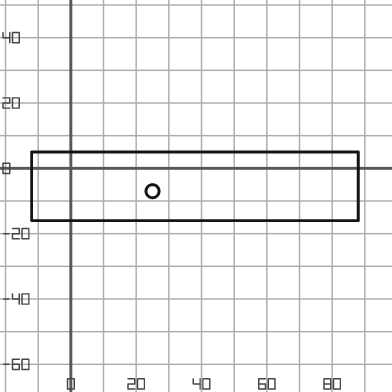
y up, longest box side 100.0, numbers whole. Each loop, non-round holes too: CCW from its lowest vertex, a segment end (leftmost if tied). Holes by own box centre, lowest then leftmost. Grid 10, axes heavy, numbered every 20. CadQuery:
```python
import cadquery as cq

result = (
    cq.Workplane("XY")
    .moveTo(-12.0, -16.0)
    .lineTo(88.0, -16.0)
    .lineTo(88.0, 5.0)
    .lineTo(-12.0, 5.0)
    .close()
    .moveTo(25.0, -7.0)
    .circle(2.0)
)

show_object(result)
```